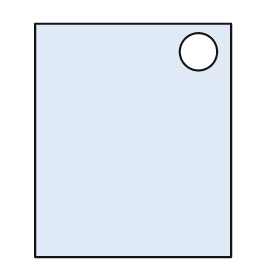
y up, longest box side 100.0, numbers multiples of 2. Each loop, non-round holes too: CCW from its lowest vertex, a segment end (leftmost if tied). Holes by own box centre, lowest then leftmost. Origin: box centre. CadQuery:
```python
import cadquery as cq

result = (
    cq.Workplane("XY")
    .moveTo(-42.0, -50.0)
    .lineTo(42.0, -50.0)
    .lineTo(42.0, 50.0)
    .lineTo(-42.0, 50.0)
    .close()
    .moveTo(28.0, 38.0)
    .circle(8.0)
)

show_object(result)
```